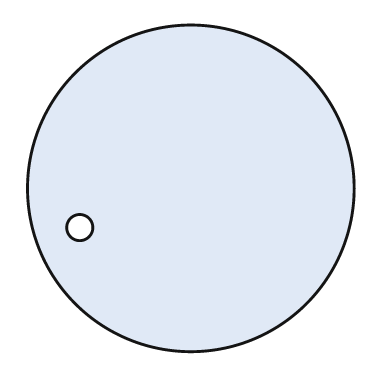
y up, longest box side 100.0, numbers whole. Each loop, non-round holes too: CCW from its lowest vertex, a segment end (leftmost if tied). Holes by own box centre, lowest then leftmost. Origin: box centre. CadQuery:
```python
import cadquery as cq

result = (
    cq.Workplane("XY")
    .moveTo(0.0, 0.0)
    .circle(50.0)
    .moveTo(-34.0, -12.0)
    .circle(4.0)
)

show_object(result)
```